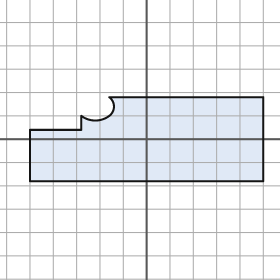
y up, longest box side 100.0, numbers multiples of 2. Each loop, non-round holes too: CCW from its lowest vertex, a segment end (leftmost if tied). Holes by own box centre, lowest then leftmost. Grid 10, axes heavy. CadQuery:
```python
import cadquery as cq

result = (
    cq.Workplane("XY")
    .moveTo(-50.0, -18.0)
    .lineTo(50.0, -18.0)
    .lineTo(50.0, 18.0)
    .lineTo(-16.0, 18.0)
    .threePointArc((-14.0, 14.0), (-16.0, 10.0))
    .threePointArc((-22.0, 8.0), (-28.0, 10.0))
    .lineTo(-28.0, 4.0)
    .lineTo(-50.0, 4.0)
    .close()
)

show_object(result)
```